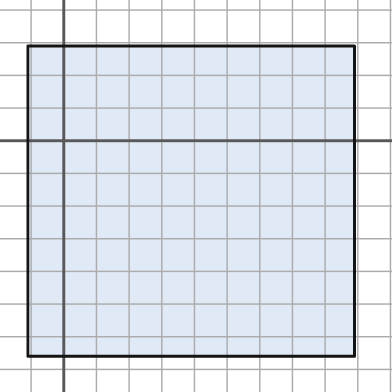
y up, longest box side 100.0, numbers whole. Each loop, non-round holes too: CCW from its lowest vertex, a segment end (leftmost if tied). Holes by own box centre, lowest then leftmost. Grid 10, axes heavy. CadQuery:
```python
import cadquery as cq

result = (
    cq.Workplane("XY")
    .moveTo(-11.0, -66.0)
    .lineTo(89.0, -66.0)
    .lineTo(89.0, 29.0)
    .lineTo(-11.0, 29.0)
    .close()
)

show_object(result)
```